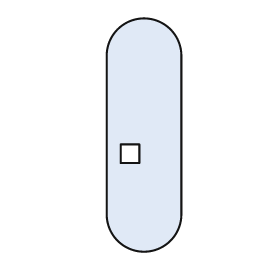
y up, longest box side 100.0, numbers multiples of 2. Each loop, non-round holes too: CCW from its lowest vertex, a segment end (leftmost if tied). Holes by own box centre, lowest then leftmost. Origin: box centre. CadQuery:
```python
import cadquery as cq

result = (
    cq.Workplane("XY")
    .moveTo(-16.0, -34.0)
    .threePointArc((0.0, -50.0), (16.0, -34.0))
    .lineTo(16.0, 34.0)
    .threePointArc((0.0, 50.0), (-16.0, 34.0))
    .close()
    .moveTo(-10.0, -12.0)
    .lineTo(-2.0, -12.0)
    .lineTo(-2.0, -4.0)
    .lineTo(-10.0, -4.0)
    .close()
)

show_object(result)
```